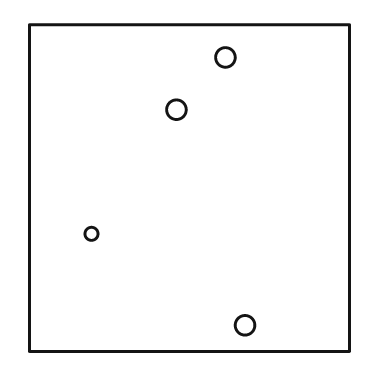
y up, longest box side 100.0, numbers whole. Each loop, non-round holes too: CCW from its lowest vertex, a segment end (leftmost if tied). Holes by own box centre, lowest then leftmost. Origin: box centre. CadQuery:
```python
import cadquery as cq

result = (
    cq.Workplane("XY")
    .moveTo(-49.0, -50.0)
    .lineTo(49.0, -50.0)
    .lineTo(49.0, 50.0)
    .lineTo(-49.0, 50.0)
    .close()
    .moveTo(17.0, -42.0)
    .circle(3.0)
    .moveTo(-30.0, -14.0)
    .circle(2.0)
    .moveTo(-4.0, 24.0)
    .circle(3.0)
    .moveTo(11.0, 40.0)
    .circle(3.0)
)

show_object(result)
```